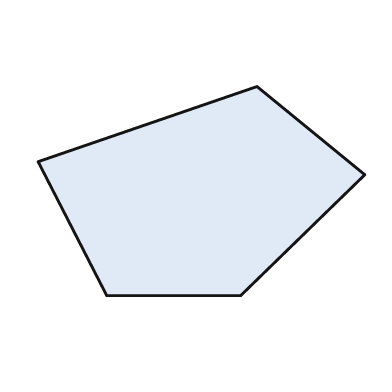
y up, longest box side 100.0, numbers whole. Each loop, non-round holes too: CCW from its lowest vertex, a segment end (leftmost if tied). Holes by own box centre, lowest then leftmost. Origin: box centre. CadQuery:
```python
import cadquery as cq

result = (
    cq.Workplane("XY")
    .moveTo(-29.0, -32.0)
    .lineTo(12.0, -32.0)
    .lineTo(50.0, 5.0)
    .lineTo(17.0, 32.0)
    .lineTo(-50.0, 9.0)
    .close()
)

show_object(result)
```